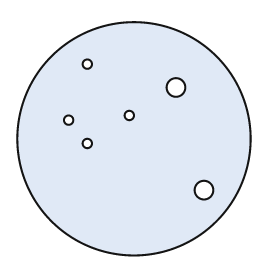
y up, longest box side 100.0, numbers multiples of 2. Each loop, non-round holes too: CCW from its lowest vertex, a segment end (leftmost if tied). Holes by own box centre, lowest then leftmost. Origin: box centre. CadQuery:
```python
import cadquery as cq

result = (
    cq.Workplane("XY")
    .moveTo(0.0, 0.0)
    .circle(50.0)
    .moveTo(30.0, -22.0)
    .circle(4.0)
    .moveTo(-20.0, -2.0)
    .circle(2.0)
    .moveTo(-28.0, 8.0)
    .circle(2.0)
    .moveTo(-2.0, 10.0)
    .circle(2.0)
    .moveTo(18.0, 22.0)
    .circle(4.0)
    .moveTo(-20.0, 32.0)
    .circle(2.0)
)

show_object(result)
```